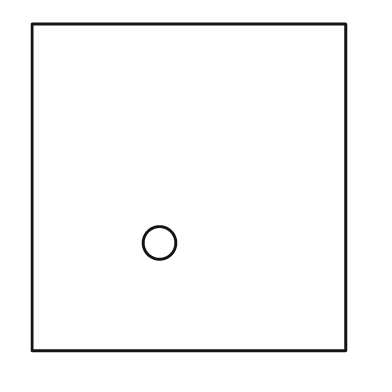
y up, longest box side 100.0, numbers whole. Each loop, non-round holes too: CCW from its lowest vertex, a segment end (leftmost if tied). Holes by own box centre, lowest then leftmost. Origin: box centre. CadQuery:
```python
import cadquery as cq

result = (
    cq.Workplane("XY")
    .moveTo(-48.0, -50.0)
    .lineTo(48.0, -50.0)
    .lineTo(48.0, 50.0)
    .lineTo(-48.0, 50.0)
    .close()
    .moveTo(-9.0, -17.0)
    .circle(5.0)
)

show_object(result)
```